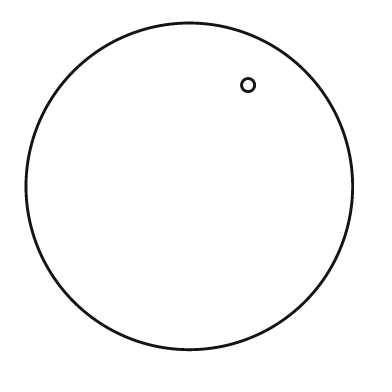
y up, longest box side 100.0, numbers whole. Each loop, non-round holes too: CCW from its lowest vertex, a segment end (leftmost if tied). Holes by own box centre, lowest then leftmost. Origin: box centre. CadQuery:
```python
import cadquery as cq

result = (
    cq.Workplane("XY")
    .moveTo(0.0, 0.0)
    .circle(50.0)
    .moveTo(18.0, 31.0)
    .circle(2.0)
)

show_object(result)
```